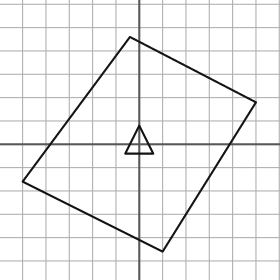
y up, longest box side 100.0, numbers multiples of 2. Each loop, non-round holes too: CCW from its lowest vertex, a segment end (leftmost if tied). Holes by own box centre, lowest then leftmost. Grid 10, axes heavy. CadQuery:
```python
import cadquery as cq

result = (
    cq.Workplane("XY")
    .moveTo(10.0, -46.0)
    .lineTo(50.0, 18.0)
    .lineTo(-4.0, 46.0)
    .lineTo(-50.0, -16.0)
    .close()
    .moveTo(-6.0, -4.0)
    .lineTo(6.0, -4.0)
    .lineTo(0.0, 8.0)
    .close()
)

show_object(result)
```